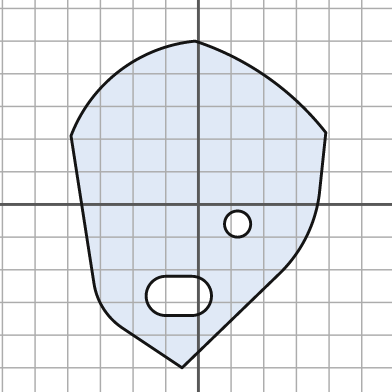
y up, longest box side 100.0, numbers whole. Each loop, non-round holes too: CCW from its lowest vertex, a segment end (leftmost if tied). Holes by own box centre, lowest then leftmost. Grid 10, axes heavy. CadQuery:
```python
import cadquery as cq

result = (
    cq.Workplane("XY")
    .moveTo(-5.0, -50.0)
    .lineTo(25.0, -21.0)
    .threePointArc((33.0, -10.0), (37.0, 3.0))
    .lineTo(39.0, 22.0)
    .threePointArc((21.0, 39.0), (-1.0, 50.0))
    .threePointArc((-24.0, 41.0), (-39.0, 21.0))
    .lineTo(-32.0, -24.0)
    .threePointArc((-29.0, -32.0), (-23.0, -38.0))
    .close()
    .moveTo(-10.0, -34.0)
    .lineTo(-2.0, -34.0)
    .threePointArc((4.0, -28.0), (-2.0, -22.0))
    .lineTo(-10.0, -22.0)
    .threePointArc((-16.0, -28.0), (-10.0, -34.0))
    .close()
    .moveTo(12.0, -6.0)
    .circle(4.0)
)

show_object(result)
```